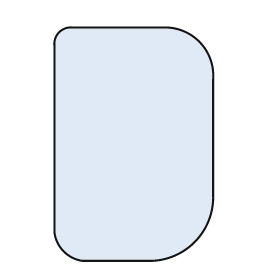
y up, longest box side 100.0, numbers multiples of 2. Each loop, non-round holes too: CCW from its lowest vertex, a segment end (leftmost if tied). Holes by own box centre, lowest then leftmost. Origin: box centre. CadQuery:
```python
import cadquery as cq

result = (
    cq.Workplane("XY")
    .moveTo(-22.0, -50.0)
    .lineTo(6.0, -50.0)
    .threePointArc((26.0, -42.0), (34.0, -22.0))
    .lineTo(34.0, 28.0)
    .threePointArc((28.0, 44.0), (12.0, 50.0))
    .lineTo(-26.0, 50.0)
    .threePointArc((-32.0, 48.0), (-34.0, 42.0))
    .lineTo(-34.0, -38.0)
    .threePointArc((-30.0, -46.0), (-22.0, -50.0))
    .close()
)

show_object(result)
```